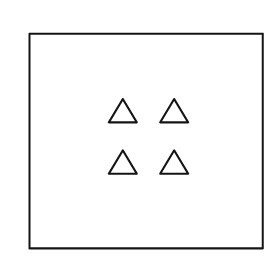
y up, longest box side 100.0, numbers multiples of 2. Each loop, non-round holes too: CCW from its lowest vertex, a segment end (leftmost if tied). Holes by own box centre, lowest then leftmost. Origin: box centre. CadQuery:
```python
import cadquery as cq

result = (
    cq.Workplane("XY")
    .moveTo(-50.0, -46.0)
    .lineTo(50.0, -46.0)
    .lineTo(50.0, 46.0)
    .lineTo(-50.0, 46.0)
    .close()
    .moveTo(-16.0, -14.0)
    .lineTo(-4.0, -14.0)
    .lineTo(-10.0, -4.0)
    .close()
    .moveTo(6.0, -14.0)
    .lineTo(18.0, -14.0)
    .lineTo(12.0, -4.0)
    .close()
    .moveTo(-16.0, 8.0)
    .lineTo(-4.0, 8.0)
    .lineTo(-10.0, 18.0)
    .close()
    .moveTo(6.0, 8.0)
    .lineTo(18.0, 8.0)
    .lineTo(12.0, 18.0)
    .close()
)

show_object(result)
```